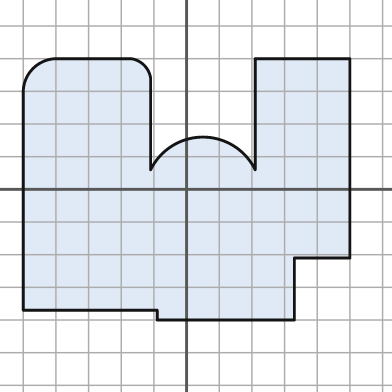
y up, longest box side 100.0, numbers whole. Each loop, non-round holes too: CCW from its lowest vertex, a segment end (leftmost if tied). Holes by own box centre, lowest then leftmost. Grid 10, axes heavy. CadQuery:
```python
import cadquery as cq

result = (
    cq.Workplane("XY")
    .moveTo(-9.0, -40.0)
    .lineTo(33.0, -40.0)
    .lineTo(33.0, -21.0)
    .lineTo(50.0, -21.0)
    .lineTo(50.0, 40.0)
    .lineTo(21.0, 40.0)
    .lineTo(21.0, 6.0)
    .threePointArc((5.0, 16.0), (-11.0, 6.0))
    .lineTo(-11.0, 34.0)
    .threePointArc((-13.0, 38.0), (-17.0, 40.0))
    .lineTo(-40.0, 40.0)
    .threePointArc((-47.0, 37.0), (-50.0, 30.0))
    .lineTo(-50.0, -37.0)
    .lineTo(-9.0, -37.0)
    .close()
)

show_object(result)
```